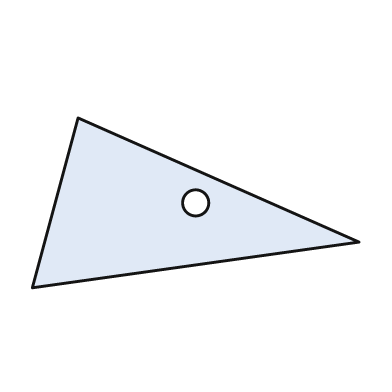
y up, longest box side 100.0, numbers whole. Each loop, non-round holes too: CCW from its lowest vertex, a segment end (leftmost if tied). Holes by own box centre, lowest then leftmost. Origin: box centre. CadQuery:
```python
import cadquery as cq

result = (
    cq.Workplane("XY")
    .moveTo(-50.0, -26.0)
    .lineTo(50.0, -12.0)
    .lineTo(-36.0, 26.0)
    .close()
    .moveTo(0.0, 0.0)
    .circle(4.0)
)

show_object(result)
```